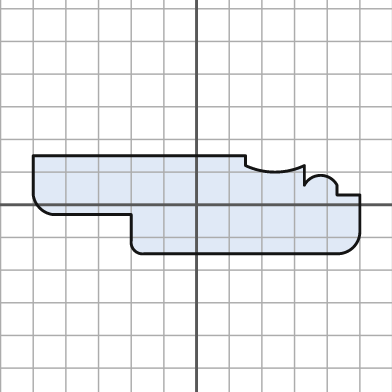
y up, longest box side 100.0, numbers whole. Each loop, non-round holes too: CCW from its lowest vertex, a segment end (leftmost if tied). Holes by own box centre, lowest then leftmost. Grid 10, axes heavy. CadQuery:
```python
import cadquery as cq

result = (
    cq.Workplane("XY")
    .moveTo(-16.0, -15.0)
    .lineTo(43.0, -15.0)
    .threePointArc((48.0, -13.0), (50.0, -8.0))
    .lineTo(50.0, 3.0)
    .lineTo(43.0, 3.0)
    .lineTo(43.0, 6.0)
    .threePointArc((38.0, 9.0), (33.0, 6.0))
    .lineTo(33.0, 12.0)
    .threePointArc((24.0, 10.0), (15.0, 12.0))
    .lineTo(15.0, 15.0)
    .lineTo(-50.0, 15.0)
    .lineTo(-50.0, 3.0)
    .threePointArc((-48.0, -1.0), (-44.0, -3.0))
    .lineTo(-20.0, -3.0)
    .lineTo(-20.0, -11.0)
    .threePointArc((-19.0, -14.0), (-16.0, -15.0))
    .close()
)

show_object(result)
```